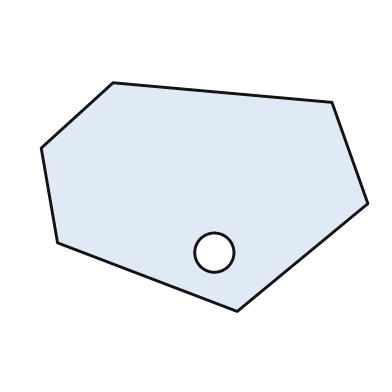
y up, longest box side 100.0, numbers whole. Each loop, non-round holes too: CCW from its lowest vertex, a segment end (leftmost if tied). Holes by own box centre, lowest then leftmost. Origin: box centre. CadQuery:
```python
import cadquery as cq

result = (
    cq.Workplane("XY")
    .moveTo(10.0, -35.0)
    .lineTo(50.0, -2.0)
    .lineTo(39.0, 29.0)
    .lineTo(-28.0, 35.0)
    .lineTo(-50.0, 15.0)
    .lineTo(-45.0, -14.0)
    .close()
    .moveTo(3.0, -17.0)
    .circle(6.0)
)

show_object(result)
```